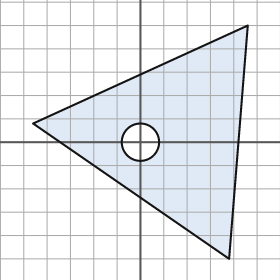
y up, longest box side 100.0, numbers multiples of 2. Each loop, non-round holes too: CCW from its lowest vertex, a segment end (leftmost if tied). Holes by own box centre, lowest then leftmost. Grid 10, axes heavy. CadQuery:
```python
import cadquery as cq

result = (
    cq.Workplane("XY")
    .moveTo(38.0, -50.0)
    .lineTo(46.0, 50.0)
    .lineTo(-46.0, 8.0)
    .close()
    .moveTo(0.0, 0.0)
    .circle(8.0)
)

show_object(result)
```